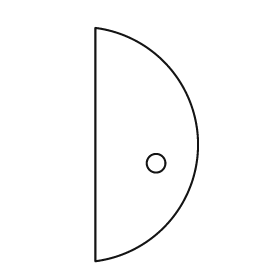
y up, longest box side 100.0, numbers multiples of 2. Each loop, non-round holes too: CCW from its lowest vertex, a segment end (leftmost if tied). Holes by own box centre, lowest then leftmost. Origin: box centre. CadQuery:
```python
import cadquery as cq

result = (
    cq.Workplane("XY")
    .moveTo(-22.0, -50.0)
    .threePointArc((22.0, 0.0), (-22.0, 50.0))
    .close()
    .moveTo(4.0, -8.0)
    .circle(4.0)
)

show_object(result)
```